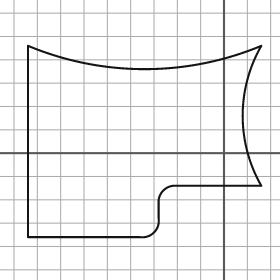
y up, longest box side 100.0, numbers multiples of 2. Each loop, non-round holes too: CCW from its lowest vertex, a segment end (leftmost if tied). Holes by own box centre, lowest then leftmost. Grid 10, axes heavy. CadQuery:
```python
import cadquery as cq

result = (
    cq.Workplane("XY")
    .moveTo(-84.0, -36.0)
    .lineTo(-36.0, -36.0)
    .threePointArc((-30.0, -34.0), (-28.0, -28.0))
    .lineTo(-28.0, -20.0)
    .threePointArc((-26.0, -16.0), (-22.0, -14.0))
    .lineTo(16.0, -14.0)
    .threePointArc((8.0, 16.0), (16.0, 46.0))
    .threePointArc((-34.0, 36.0), (-84.0, 46.0))
    .close()
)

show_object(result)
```